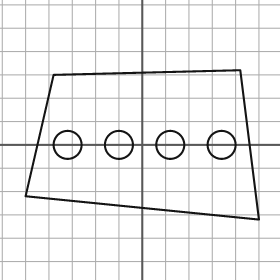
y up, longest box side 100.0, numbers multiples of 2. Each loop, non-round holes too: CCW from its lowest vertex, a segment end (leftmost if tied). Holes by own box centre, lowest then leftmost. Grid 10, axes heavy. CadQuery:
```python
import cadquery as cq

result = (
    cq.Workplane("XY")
    .moveTo(50.0, -32.0)
    .lineTo(42.0, 32.0)
    .lineTo(-38.0, 30.0)
    .lineTo(-50.0, -22.0)
    .close()
    .moveTo(-32.0, 0.0)
    .circle(6.0)
    .moveTo(-10.0, 0.0)
    .circle(6.0)
    .moveTo(12.0, 0.0)
    .circle(6.0)
    .moveTo(34.0, 0.0)
    .circle(6.0)
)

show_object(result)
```